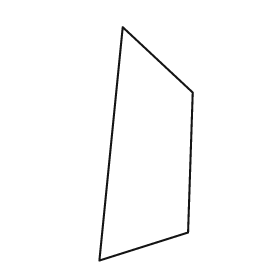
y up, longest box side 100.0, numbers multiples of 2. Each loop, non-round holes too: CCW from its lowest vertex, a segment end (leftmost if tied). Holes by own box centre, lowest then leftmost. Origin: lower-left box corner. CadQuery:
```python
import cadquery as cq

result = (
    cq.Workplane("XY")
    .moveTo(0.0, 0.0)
    .lineTo(38.0, 12.0)
    .lineTo(40.0, 72.0)
    .lineTo(10.0, 100.0)
    .close()
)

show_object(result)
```